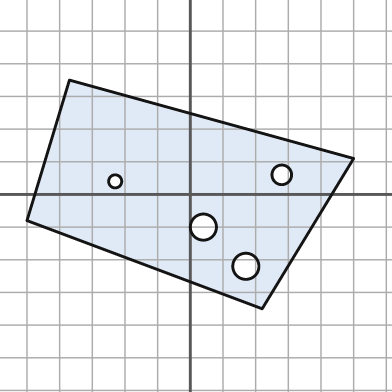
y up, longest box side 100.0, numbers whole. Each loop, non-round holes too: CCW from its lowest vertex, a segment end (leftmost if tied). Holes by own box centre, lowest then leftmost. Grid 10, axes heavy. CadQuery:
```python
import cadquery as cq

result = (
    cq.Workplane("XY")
    .moveTo(22.0, -35.0)
    .lineTo(50.0, 11.0)
    .lineTo(-37.0, 35.0)
    .lineTo(-50.0, -8.0)
    .close()
    .moveTo(17.0, -22.0)
    .circle(4.0)
    .moveTo(4.0, -10.0)
    .circle(4.0)
    .moveTo(-23.0, 4.0)
    .circle(2.0)
    .moveTo(28.0, 6.0)
    .circle(3.0)
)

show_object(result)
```